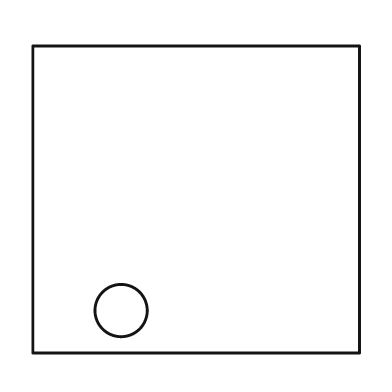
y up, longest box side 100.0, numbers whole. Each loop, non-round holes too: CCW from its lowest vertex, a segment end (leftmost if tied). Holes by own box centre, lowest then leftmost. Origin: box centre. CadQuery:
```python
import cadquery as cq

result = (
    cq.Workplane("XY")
    .moveTo(-50.0, -47.0)
    .lineTo(50.0, -47.0)
    .lineTo(50.0, 47.0)
    .lineTo(-50.0, 47.0)
    .close()
    .moveTo(-23.0, -34.0)
    .circle(8.0)
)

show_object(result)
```